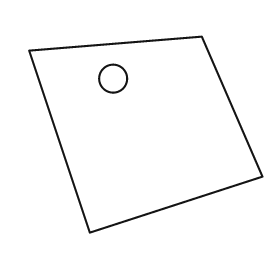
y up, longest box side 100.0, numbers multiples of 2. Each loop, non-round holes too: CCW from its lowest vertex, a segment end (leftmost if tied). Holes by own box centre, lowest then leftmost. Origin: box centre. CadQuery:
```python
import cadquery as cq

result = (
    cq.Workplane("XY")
    .moveTo(-24.0, -42.0)
    .lineTo(50.0, -18.0)
    .lineTo(24.0, 42.0)
    .lineTo(-50.0, 36.0)
    .close()
    .moveTo(-14.0, 24.0)
    .circle(6.0)
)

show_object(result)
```